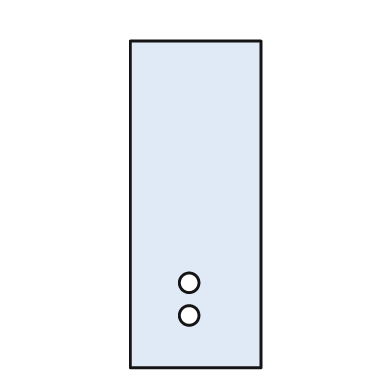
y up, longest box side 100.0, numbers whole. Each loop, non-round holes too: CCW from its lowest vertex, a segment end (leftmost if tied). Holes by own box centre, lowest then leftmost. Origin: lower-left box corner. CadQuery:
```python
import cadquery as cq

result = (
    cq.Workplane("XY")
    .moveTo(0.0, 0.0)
    .lineTo(40.0, 0.0)
    .lineTo(40.0, 100.0)
    .lineTo(0.0, 100.0)
    .close()
    .moveTo(18.0, 16.0)
    .circle(3.0)
    .moveTo(18.0, 26.0)
    .circle(3.0)
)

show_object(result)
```